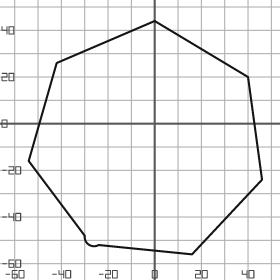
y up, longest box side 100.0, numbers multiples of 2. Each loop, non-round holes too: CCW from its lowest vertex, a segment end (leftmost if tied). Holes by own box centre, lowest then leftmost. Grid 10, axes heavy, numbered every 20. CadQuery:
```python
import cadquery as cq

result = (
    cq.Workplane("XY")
    .moveTo(16.0, -56.0)
    .lineTo(46.0, -24.0)
    .lineTo(40.0, 20.0)
    .lineTo(0.0, 44.0)
    .lineTo(-42.0, 26.0)
    .lineTo(-54.0, -16.0)
    .lineTo(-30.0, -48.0)
    .threePointArc((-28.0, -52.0), (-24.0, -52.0))
    .close()
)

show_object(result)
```